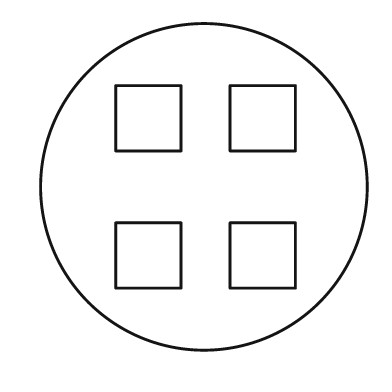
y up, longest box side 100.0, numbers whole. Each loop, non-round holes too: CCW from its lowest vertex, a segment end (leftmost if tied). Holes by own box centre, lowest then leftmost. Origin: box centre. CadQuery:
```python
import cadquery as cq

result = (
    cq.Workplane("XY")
    .moveTo(0.0, 0.0)
    .circle(50.0)
    .moveTo(-27.0, -31.0)
    .lineTo(-7.0, -31.0)
    .lineTo(-7.0, -11.0)
    .lineTo(-27.0, -11.0)
    .close()
    .moveTo(8.0, -31.0)
    .lineTo(28.0, -31.0)
    .lineTo(28.0, -11.0)
    .lineTo(8.0, -11.0)
    .close()
    .moveTo(-27.0, 11.0)
    .lineTo(-7.0, 11.0)
    .lineTo(-7.0, 31.0)
    .lineTo(-27.0, 31.0)
    .close()
    .moveTo(8.0, 11.0)
    .lineTo(28.0, 11.0)
    .lineTo(28.0, 31.0)
    .lineTo(8.0, 31.0)
    .close()
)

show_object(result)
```